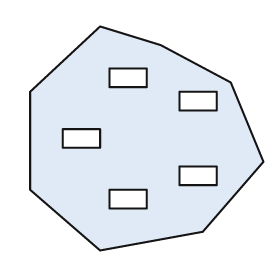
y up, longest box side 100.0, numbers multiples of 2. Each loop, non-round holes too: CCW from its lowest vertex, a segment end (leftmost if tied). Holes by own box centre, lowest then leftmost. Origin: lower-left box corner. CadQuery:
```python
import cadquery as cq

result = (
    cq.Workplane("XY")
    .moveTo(30.0, 0.0)
    .lineTo(74.0, 8.0)
    .lineTo(100.0, 38.0)
    .lineTo(86.0, 72.0)
    .lineTo(56.0, 88.0)
    .lineTo(30.0, 96.0)
    .lineTo(0.0, 68.0)
    .lineTo(0.0, 26.0)
    .close()
    .moveTo(34.0, 18.0)
    .lineTo(50.0, 18.0)
    .lineTo(50.0, 26.0)
    .lineTo(34.0, 26.0)
    .close()
    .moveTo(64.0, 28.0)
    .lineTo(80.0, 28.0)
    .lineTo(80.0, 36.0)
    .lineTo(64.0, 36.0)
    .close()
    .moveTo(14.0, 44.0)
    .lineTo(30.0, 44.0)
    .lineTo(30.0, 52.0)
    .lineTo(14.0, 52.0)
    .close()
    .moveTo(64.0, 60.0)
    .lineTo(80.0, 60.0)
    .lineTo(80.0, 68.0)
    .lineTo(64.0, 68.0)
    .close()
    .moveTo(34.0, 70.0)
    .lineTo(50.0, 70.0)
    .lineTo(50.0, 78.0)
    .lineTo(34.0, 78.0)
    .close()
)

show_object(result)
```